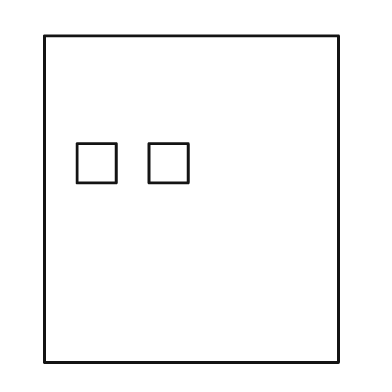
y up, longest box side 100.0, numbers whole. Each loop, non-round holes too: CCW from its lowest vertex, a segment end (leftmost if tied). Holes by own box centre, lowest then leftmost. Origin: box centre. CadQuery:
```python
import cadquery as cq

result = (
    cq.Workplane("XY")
    .moveTo(-45.0, -50.0)
    .lineTo(45.0, -50.0)
    .lineTo(45.0, 50.0)
    .lineTo(-45.0, 50.0)
    .close()
    .moveTo(-35.0, 5.0)
    .lineTo(-23.0, 5.0)
    .lineTo(-23.0, 17.0)
    .lineTo(-35.0, 17.0)
    .close()
    .moveTo(-13.0, 5.0)
    .lineTo(-1.0, 5.0)
    .lineTo(-1.0, 17.0)
    .lineTo(-13.0, 17.0)
    .close()
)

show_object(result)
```